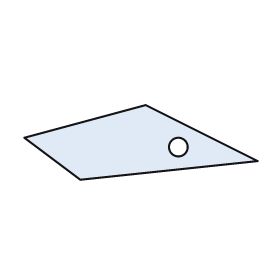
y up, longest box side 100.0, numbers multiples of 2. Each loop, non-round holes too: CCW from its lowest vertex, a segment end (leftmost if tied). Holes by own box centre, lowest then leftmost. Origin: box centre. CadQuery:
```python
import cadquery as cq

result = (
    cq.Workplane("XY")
    .moveTo(-26.0, -16.0)
    .lineTo(50.0, -8.0)
    .lineTo(2.0, 16.0)
    .lineTo(-50.0, 2.0)
    .close()
    .moveTo(16.0, -2.0)
    .circle(4.0)
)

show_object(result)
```